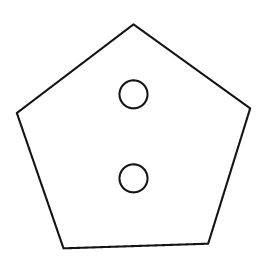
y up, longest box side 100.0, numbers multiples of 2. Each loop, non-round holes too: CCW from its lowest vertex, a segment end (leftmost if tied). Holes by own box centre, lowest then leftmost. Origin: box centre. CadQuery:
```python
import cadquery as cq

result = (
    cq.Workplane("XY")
    .moveTo(-30.0, -48.0)
    .lineTo(32.0, -46.0)
    .lineTo(50.0, 12.0)
    .lineTo(0.0, 48.0)
    .lineTo(-50.0, 10.0)
    .close()
    .moveTo(0.0, -18.0)
    .circle(6.0)
    .moveTo(0.0, 18.0)
    .circle(6.0)
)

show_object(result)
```